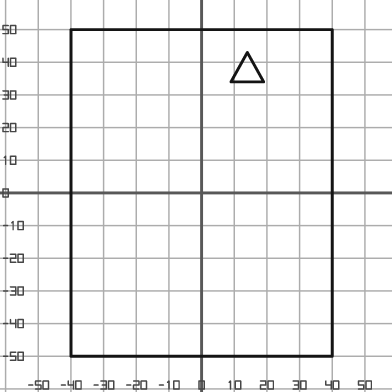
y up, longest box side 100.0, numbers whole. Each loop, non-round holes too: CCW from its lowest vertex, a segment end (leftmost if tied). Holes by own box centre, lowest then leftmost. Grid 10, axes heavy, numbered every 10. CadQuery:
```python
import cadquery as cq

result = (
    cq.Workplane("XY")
    .moveTo(-40.0, -50.0)
    .lineTo(40.0, -50.0)
    .lineTo(40.0, 50.0)
    .lineTo(-40.0, 50.0)
    .close()
    .moveTo(9.0, 34.0)
    .lineTo(19.0, 34.0)
    .lineTo(14.0, 43.0)
    .close()
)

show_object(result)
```